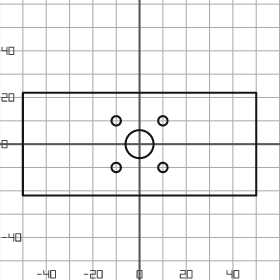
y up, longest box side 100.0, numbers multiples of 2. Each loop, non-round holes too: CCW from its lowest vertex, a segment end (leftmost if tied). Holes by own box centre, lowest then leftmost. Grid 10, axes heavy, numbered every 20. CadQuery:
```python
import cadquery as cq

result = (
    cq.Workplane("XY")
    .moveTo(-50.0, -22.0)
    .lineTo(50.0, -22.0)
    .lineTo(50.0, 22.0)
    .lineTo(-50.0, 22.0)
    .close()
    .moveTo(-10.0, -10.0)
    .circle(2.0)
    .moveTo(10.0, -10.0)
    .circle(2.0)
    .moveTo(0.0, 0.0)
    .circle(6.0)
    .moveTo(-10.0, 10.0)
    .circle(2.0)
    .moveTo(10.0, 10.0)
    .circle(2.0)
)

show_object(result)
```